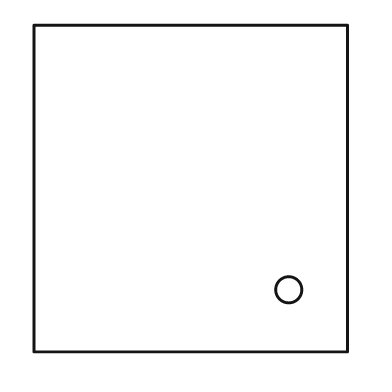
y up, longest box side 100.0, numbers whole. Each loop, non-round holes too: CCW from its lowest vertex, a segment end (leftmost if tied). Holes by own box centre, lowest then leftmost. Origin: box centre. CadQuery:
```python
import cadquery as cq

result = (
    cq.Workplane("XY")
    .moveTo(-48.0, -50.0)
    .lineTo(48.0, -50.0)
    .lineTo(48.0, 50.0)
    .lineTo(-48.0, 50.0)
    .close()
    .moveTo(30.0, -31.0)
    .circle(4.0)
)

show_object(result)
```